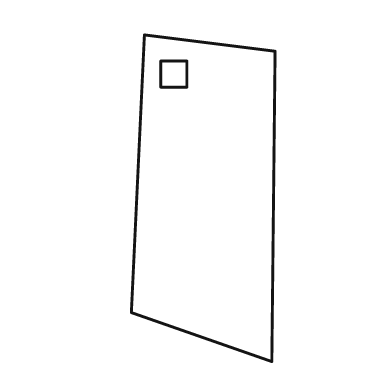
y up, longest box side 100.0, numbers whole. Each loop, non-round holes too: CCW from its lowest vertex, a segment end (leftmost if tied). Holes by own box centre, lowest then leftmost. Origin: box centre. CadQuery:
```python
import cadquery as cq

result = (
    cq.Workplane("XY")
    .moveTo(21.0, -50.0)
    .lineTo(22.0, 45.0)
    .lineTo(-18.0, 50.0)
    .lineTo(-22.0, -35.0)
    .close()
    .moveTo(-13.0, 34.0)
    .lineTo(-5.0, 34.0)
    .lineTo(-5.0, 42.0)
    .lineTo(-13.0, 42.0)
    .close()
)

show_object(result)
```